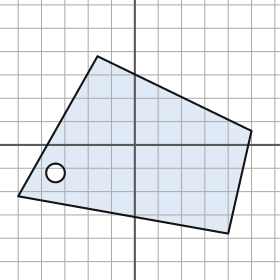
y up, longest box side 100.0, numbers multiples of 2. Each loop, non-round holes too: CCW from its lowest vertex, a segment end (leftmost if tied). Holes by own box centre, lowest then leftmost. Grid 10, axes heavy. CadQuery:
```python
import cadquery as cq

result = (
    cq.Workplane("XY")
    .moveTo(40.0, -38.0)
    .lineTo(50.0, 6.0)
    .lineTo(-16.0, 38.0)
    .lineTo(-50.0, -22.0)
    .close()
    .moveTo(-34.0, -12.0)
    .circle(4.0)
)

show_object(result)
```